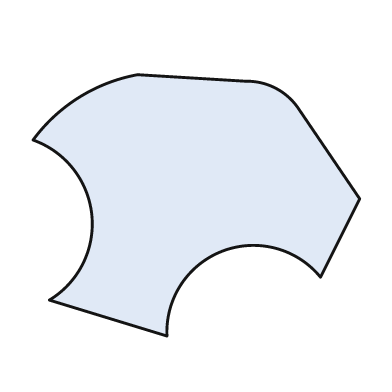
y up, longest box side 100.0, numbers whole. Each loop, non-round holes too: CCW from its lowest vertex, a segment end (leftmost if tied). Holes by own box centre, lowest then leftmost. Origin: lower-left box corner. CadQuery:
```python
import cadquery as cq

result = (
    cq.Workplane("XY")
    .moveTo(41.0, 0.0)
    .threePointArc((58.0, 26.0), (88.0, 18.0))
    .lineTo(100.0, 42.0)
    .lineTo(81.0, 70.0)
    .threePointArc((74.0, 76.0), (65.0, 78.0))
    .lineTo(32.0, 80.0)
    .threePointArc((14.0, 73.0), (0.0, 60.0))
    .threePointArc((18.0, 37.0), (5.0, 11.0))
    .close()
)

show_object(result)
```